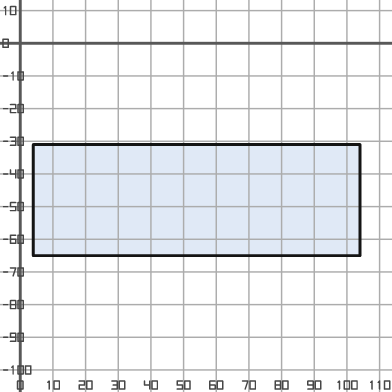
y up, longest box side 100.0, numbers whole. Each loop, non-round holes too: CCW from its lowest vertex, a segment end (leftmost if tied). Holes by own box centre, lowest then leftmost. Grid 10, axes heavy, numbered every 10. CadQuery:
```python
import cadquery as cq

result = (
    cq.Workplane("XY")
    .moveTo(4.0, -65.0)
    .lineTo(104.0, -65.0)
    .lineTo(104.0, -31.0)
    .lineTo(4.0, -31.0)
    .close()
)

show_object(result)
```